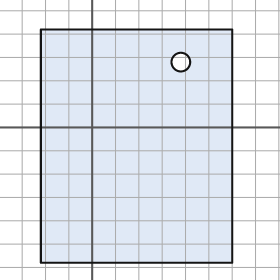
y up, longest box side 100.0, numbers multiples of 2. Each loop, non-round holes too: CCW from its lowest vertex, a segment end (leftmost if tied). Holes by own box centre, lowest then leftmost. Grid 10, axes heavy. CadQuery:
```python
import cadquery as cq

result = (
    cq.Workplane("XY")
    .moveTo(-22.0, -58.0)
    .lineTo(60.0, -58.0)
    .lineTo(60.0, 42.0)
    .lineTo(-22.0, 42.0)
    .close()
    .moveTo(38.0, 28.0)
    .circle(4.0)
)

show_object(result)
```